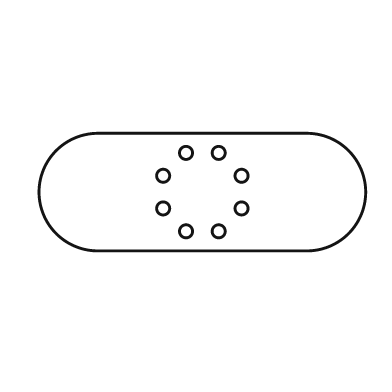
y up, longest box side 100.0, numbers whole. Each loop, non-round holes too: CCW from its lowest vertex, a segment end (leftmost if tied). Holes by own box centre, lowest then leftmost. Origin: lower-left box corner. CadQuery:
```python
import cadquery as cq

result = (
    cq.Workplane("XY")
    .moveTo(18.0, 0.0)
    .lineTo(82.0, 0.0)
    .threePointArc((100.0, 18.0), (82.0, 36.0))
    .lineTo(18.0, 36.0)
    .threePointArc((0.0, 18.0), (18.0, 0.0))
    .close()
    .moveTo(45.0, 6.0)
    .circle(2.0)
    .moveTo(55.0, 6.0)
    .circle(2.0)
    .moveTo(38.0, 13.0)
    .circle(2.0)
    .moveTo(62.0, 13.0)
    .circle(2.0)
    .moveTo(38.0, 23.0)
    .circle(2.0)
    .moveTo(62.0, 23.0)
    .circle(2.0)
    .moveTo(45.0, 30.0)
    .circle(2.0)
    .moveTo(55.0, 30.0)
    .circle(2.0)
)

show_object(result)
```